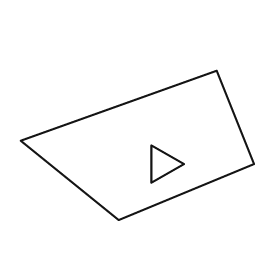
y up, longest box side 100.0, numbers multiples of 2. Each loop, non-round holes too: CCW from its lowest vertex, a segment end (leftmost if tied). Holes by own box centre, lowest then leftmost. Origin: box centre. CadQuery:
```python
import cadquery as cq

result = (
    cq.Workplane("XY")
    .moveTo(-8.0, -32.0)
    .lineTo(50.0, -8.0)
    .lineTo(34.0, 32.0)
    .lineTo(-50.0, 2.0)
    .close()
    .moveTo(6.0, -16.0)
    .lineTo(20.0, -8.0)
    .lineTo(6.0, 0.0)
    .close()
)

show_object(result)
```